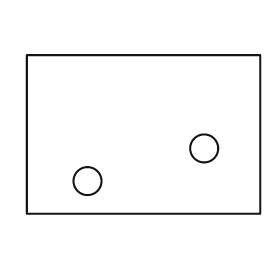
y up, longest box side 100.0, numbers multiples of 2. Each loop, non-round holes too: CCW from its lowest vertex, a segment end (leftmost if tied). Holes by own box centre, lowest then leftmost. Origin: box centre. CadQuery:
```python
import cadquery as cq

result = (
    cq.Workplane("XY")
    .moveTo(-50.0, -34.0)
    .lineTo(50.0, -34.0)
    .lineTo(50.0, 34.0)
    .lineTo(-50.0, 34.0)
    .close()
    .moveTo(-24.0, -20.0)
    .circle(6.0)
    .moveTo(26.0, -6.0)
    .circle(6.0)
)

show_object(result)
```